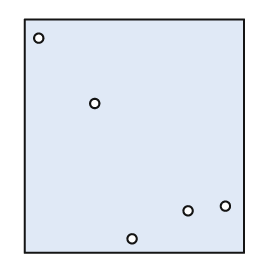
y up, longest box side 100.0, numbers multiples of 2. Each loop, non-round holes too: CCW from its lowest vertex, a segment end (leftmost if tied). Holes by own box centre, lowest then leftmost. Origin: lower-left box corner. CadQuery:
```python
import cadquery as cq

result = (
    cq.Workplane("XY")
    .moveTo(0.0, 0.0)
    .lineTo(94.0, 0.0)
    .lineTo(94.0, 100.0)
    .lineTo(0.0, 100.0)
    .close()
    .moveTo(46.0, 6.0)
    .circle(2.0)
    .moveTo(70.0, 18.0)
    .circle(2.0)
    .moveTo(86.0, 20.0)
    .circle(2.0)
    .moveTo(30.0, 64.0)
    .circle(2.0)
    .moveTo(6.0, 92.0)
    .circle(2.0)
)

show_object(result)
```